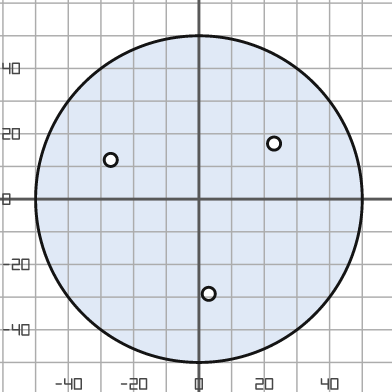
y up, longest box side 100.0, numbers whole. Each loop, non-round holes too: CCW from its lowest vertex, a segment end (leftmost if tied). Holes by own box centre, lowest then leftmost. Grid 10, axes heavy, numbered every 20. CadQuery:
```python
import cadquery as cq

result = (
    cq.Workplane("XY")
    .moveTo(0.0, 0.0)
    .circle(50.0)
    .moveTo(3.0, -29.0)
    .circle(2.0)
    .moveTo(-27.0, 12.0)
    .circle(2.0)
    .moveTo(23.0, 17.0)
    .circle(2.0)
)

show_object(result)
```